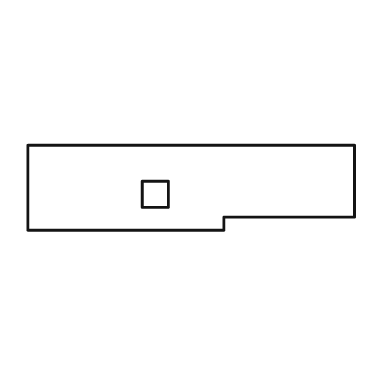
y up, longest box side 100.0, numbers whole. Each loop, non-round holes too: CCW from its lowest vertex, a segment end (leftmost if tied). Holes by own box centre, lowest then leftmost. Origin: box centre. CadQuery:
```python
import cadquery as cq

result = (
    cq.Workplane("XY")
    .moveTo(-50.0, -13.0)
    .lineTo(10.0, -13.0)
    .lineTo(10.0, -9.0)
    .lineTo(50.0, -9.0)
    .lineTo(50.0, 13.0)
    .lineTo(-50.0, 13.0)
    .close()
    .moveTo(-15.0, -6.0)
    .lineTo(-7.0, -6.0)
    .lineTo(-7.0, 2.0)
    .lineTo(-15.0, 2.0)
    .close()
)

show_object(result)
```